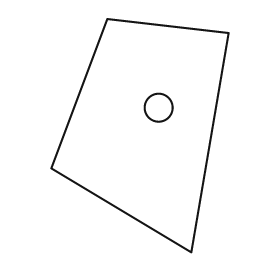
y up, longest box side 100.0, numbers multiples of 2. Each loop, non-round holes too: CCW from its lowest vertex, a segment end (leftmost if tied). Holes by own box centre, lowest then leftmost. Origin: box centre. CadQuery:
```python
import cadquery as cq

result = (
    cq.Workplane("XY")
    .moveTo(22.0, -50.0)
    .lineTo(38.0, 44.0)
    .lineTo(-14.0, 50.0)
    .lineTo(-38.0, -14.0)
    .close()
    .moveTo(8.0, 12.0)
    .circle(6.0)
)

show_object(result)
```